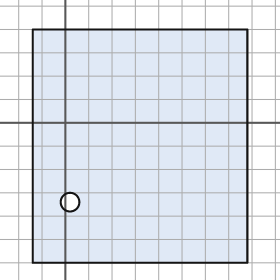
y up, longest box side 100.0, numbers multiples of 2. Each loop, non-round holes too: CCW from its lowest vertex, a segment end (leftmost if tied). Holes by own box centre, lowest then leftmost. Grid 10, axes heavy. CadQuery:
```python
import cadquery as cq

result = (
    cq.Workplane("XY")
    .moveTo(-14.0, -60.0)
    .lineTo(78.0, -60.0)
    .lineTo(78.0, 40.0)
    .lineTo(-14.0, 40.0)
    .close()
    .moveTo(2.0, -34.0)
    .circle(4.0)
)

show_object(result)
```